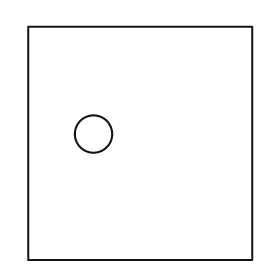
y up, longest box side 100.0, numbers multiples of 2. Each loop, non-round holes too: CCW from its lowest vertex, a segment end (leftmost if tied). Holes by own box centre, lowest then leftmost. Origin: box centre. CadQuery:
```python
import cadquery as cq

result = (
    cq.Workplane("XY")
    .moveTo(-48.0, -50.0)
    .lineTo(48.0, -50.0)
    .lineTo(48.0, 50.0)
    .lineTo(-48.0, 50.0)
    .close()
    .moveTo(-20.0, 4.0)
    .circle(8.0)
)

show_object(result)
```